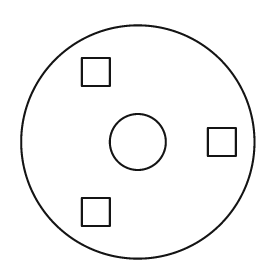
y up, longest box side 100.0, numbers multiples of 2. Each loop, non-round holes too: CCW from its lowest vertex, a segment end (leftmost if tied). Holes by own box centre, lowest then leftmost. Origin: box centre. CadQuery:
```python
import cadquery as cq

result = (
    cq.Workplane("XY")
    .moveTo(0.0, 0.0)
    .circle(50.0)
    .moveTo(-24.0, -36.0)
    .lineTo(-12.0, -36.0)
    .lineTo(-12.0, -24.0)
    .lineTo(-24.0, -24.0)
    .close()
    .moveTo(0.0, 0.0)
    .circle(12.0)
    .moveTo(30.0, -6.0)
    .lineTo(42.0, -6.0)
    .lineTo(42.0, 6.0)
    .lineTo(30.0, 6.0)
    .close()
    .moveTo(-24.0, 24.0)
    .lineTo(-12.0, 24.0)
    .lineTo(-12.0, 36.0)
    .lineTo(-24.0, 36.0)
    .close()
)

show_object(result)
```